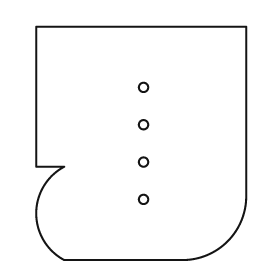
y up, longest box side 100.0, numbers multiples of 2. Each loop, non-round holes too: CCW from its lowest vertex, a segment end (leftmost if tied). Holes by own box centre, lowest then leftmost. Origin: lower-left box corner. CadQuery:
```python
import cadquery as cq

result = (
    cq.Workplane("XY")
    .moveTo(12.0, 0.0)
    .lineTo(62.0, 0.0)
    .threePointArc((82.0, 8.0), (90.0, 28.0))
    .lineTo(90.0, 100.0)
    .lineTo(0.0, 100.0)
    .lineTo(0.0, 40.0)
    .lineTo(12.0, 40.0)
    .threePointArc((0.0, 20.0), (12.0, 0.0))
    .close()
    .moveTo(46.0, 26.0)
    .circle(2.0)
    .moveTo(46.0, 42.0)
    .circle(2.0)
    .moveTo(46.0, 58.0)
    .circle(2.0)
    .moveTo(46.0, 74.0)
    .circle(2.0)
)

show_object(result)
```